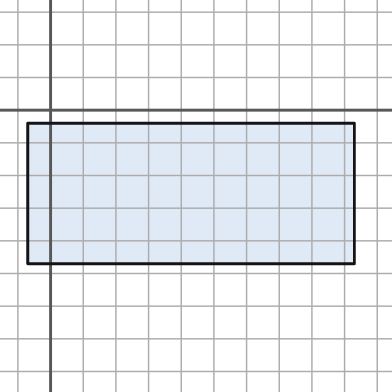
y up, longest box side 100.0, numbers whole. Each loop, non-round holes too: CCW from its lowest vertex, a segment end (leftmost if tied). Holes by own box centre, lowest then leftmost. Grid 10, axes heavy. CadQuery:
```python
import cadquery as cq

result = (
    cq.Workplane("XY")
    .moveTo(-7.0, -47.0)
    .lineTo(93.0, -47.0)
    .lineTo(93.0, -4.0)
    .lineTo(-7.0, -4.0)
    .close()
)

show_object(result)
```